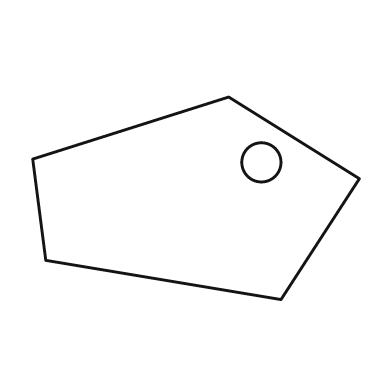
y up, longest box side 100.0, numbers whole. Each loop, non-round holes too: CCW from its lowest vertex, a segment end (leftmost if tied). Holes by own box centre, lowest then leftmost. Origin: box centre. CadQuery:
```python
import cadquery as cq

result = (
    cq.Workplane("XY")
    .moveTo(26.0, -31.0)
    .lineTo(50.0, 6.0)
    .lineTo(10.0, 31.0)
    .lineTo(-50.0, 12.0)
    .lineTo(-46.0, -19.0)
    .close()
    .moveTo(20.0, 11.0)
    .circle(6.0)
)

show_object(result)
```